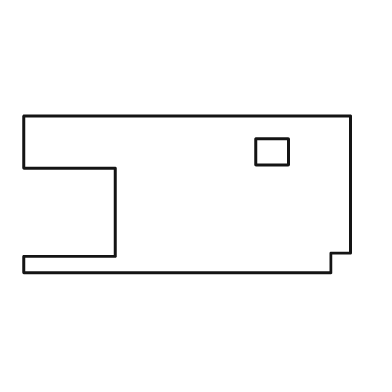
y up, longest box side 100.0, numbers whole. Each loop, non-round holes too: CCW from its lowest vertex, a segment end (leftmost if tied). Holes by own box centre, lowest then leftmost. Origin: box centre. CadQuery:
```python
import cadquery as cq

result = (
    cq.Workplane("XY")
    .moveTo(-50.0, -24.0)
    .lineTo(44.0, -24.0)
    .lineTo(44.0, -18.0)
    .lineTo(50.0, -18.0)
    .lineTo(50.0, 24.0)
    .lineTo(-50.0, 24.0)
    .lineTo(-50.0, 8.0)
    .lineTo(-22.0, 8.0)
    .lineTo(-22.0, -19.0)
    .lineTo(-50.0, -19.0)
    .close()
    .moveTo(21.0, 9.0)
    .lineTo(31.0, 9.0)
    .lineTo(31.0, 17.0)
    .lineTo(21.0, 17.0)
    .close()
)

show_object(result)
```